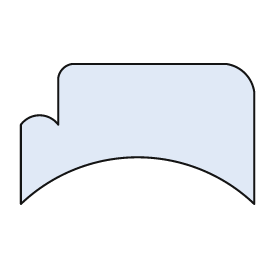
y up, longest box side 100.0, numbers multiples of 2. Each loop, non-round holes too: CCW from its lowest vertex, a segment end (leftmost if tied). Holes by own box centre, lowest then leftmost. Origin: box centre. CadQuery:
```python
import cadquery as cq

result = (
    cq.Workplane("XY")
    .moveTo(-50.0, -30.0)
    .threePointArc((0.0, -10.0), (50.0, -30.0))
    .lineTo(50.0, 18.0)
    .threePointArc((46.0, 26.0), (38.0, 30.0))
    .lineTo(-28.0, 30.0)
    .threePointArc((-32.0, 28.0), (-34.0, 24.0))
    .lineTo(-34.0, 4.0)
    .threePointArc((-42.0, 8.0), (-50.0, 4.0))
    .close()
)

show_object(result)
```